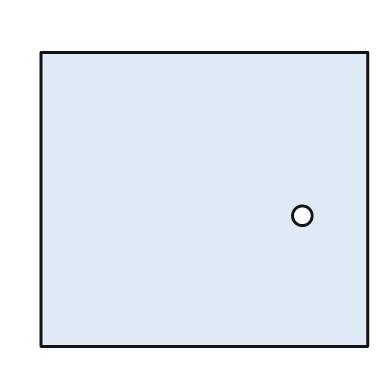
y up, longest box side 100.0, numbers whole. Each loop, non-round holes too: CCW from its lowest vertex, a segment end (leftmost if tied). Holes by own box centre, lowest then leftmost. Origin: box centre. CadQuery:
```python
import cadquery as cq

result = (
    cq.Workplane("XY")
    .moveTo(-50.0, -45.0)
    .lineTo(50.0, -45.0)
    .lineTo(50.0, 45.0)
    .lineTo(-50.0, 45.0)
    .close()
    .moveTo(30.0, -5.0)
    .circle(3.0)
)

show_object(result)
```